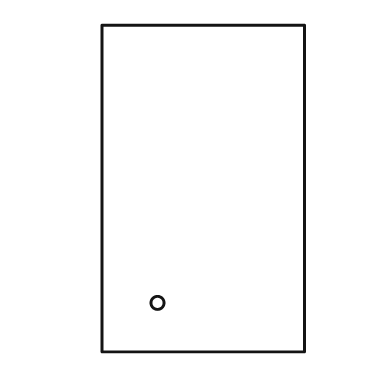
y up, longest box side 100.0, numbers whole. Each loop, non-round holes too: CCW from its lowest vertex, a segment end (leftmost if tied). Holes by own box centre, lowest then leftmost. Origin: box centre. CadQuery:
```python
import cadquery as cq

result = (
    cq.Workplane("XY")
    .moveTo(-31.0, -50.0)
    .lineTo(31.0, -50.0)
    .lineTo(31.0, 50.0)
    .lineTo(-31.0, 50.0)
    .close()
    .moveTo(-14.0, -35.0)
    .circle(2.0)
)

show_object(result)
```